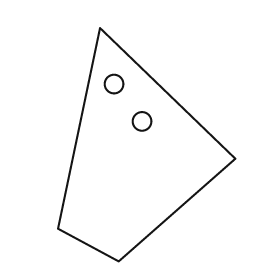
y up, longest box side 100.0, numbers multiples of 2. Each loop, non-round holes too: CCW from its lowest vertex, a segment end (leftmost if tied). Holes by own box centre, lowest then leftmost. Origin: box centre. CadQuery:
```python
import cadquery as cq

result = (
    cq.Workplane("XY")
    .moveTo(-12.0, -50.0)
    .lineTo(38.0, -6.0)
    .lineTo(-20.0, 50.0)
    .lineTo(-38.0, -36.0)
    .close()
    .moveTo(-2.0, 10.0)
    .circle(4.0)
    .moveTo(-14.0, 26.0)
    .circle(4.0)
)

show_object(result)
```